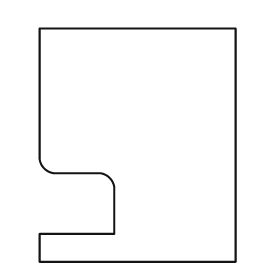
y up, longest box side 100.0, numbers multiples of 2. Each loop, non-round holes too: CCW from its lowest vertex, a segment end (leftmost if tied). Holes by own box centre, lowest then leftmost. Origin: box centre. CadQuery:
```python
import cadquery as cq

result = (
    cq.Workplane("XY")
    .moveTo(-42.0, -50.0)
    .lineTo(42.0, -50.0)
    .lineTo(42.0, 50.0)
    .lineTo(-42.0, 50.0)
    .lineTo(-42.0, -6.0)
    .threePointArc((-40.0, -10.0), (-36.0, -12.0))
    .lineTo(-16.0, -12.0)
    .threePointArc((-12.0, -14.0), (-10.0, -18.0))
    .lineTo(-10.0, -38.0)
    .lineTo(-42.0, -38.0)
    .close()
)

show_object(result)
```